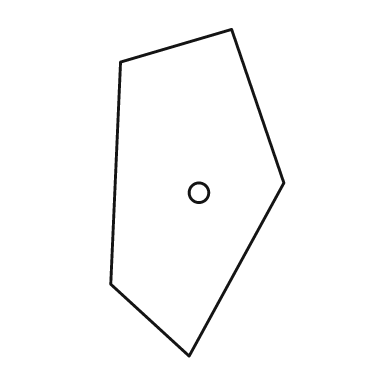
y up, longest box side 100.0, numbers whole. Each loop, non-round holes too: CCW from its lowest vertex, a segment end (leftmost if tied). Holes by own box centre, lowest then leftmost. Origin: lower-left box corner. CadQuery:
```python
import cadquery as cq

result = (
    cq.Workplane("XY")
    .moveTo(24.0, 0.0)
    .lineTo(53.0, 53.0)
    .lineTo(37.0, 100.0)
    .lineTo(3.0, 90.0)
    .lineTo(0.0, 22.0)
    .close()
    .moveTo(27.0, 50.0)
    .circle(3.0)
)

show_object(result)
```